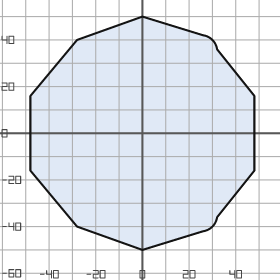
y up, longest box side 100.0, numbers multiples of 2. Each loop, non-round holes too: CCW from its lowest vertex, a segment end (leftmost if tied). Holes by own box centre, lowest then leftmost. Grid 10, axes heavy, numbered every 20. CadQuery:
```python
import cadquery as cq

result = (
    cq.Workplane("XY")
    .moveTo(0.0, -50.0)
    .lineTo(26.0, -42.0)
    .threePointArc((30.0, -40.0), (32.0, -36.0))
    .lineTo(48.0, -16.0)
    .lineTo(48.0, 16.0)
    .lineTo(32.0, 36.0)
    .threePointArc((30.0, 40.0), (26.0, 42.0))
    .lineTo(0.0, 50.0)
    .lineTo(-28.0, 40.0)
    .lineTo(-48.0, 16.0)
    .lineTo(-48.0, -16.0)
    .lineTo(-28.0, -40.0)
    .close()
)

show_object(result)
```